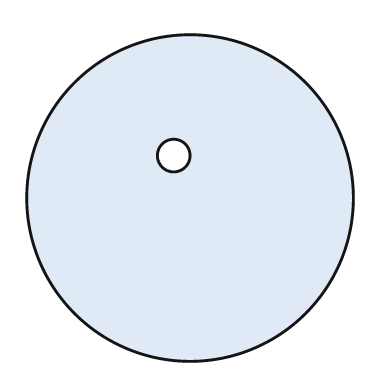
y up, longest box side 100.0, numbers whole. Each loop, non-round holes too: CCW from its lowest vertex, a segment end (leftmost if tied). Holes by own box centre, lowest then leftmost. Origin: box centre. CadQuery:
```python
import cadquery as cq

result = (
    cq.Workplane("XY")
    .moveTo(0.0, 0.0)
    .circle(50.0)
    .moveTo(-5.0, 13.0)
    .circle(5.0)
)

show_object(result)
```